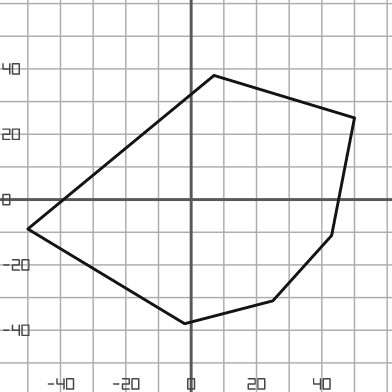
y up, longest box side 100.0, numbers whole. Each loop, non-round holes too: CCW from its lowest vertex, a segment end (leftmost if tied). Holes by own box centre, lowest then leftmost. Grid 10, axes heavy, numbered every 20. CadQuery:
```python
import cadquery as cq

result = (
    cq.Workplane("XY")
    .moveTo(-2.0, -38.0)
    .lineTo(25.0, -31.0)
    .lineTo(43.0, -11.0)
    .lineTo(50.0, 25.0)
    .lineTo(7.0, 38.0)
    .lineTo(-50.0, -9.0)
    .close()
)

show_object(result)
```